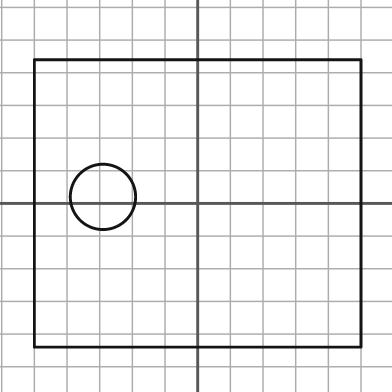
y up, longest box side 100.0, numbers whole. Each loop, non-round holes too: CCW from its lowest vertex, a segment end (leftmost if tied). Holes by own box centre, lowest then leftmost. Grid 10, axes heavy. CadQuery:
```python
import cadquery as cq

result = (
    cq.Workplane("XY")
    .moveTo(-50.0, -44.0)
    .lineTo(50.0, -44.0)
    .lineTo(50.0, 44.0)
    .lineTo(-50.0, 44.0)
    .close()
    .moveTo(-29.0, 2.0)
    .circle(10.0)
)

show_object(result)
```